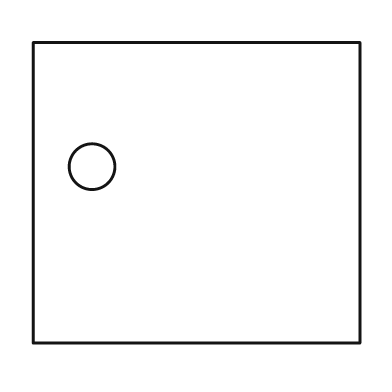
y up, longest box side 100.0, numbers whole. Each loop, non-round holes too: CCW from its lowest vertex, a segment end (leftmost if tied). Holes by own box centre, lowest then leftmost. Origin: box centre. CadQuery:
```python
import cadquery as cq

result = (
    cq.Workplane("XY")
    .moveTo(-50.0, -46.0)
    .lineTo(50.0, -46.0)
    .lineTo(50.0, 46.0)
    .lineTo(-50.0, 46.0)
    .close()
    .moveTo(-32.0, 8.0)
    .circle(7.0)
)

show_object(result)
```